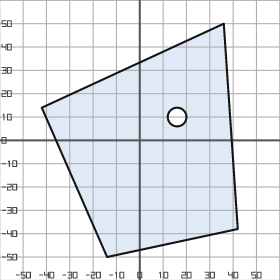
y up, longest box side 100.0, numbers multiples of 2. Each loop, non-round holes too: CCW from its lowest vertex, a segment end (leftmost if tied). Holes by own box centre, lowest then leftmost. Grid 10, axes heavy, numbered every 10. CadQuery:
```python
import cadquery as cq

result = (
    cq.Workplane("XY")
    .moveTo(-14.0, -50.0)
    .lineTo(42.0, -38.0)
    .lineTo(36.0, 50.0)
    .lineTo(-42.0, 14.0)
    .close()
    .moveTo(16.0, 10.0)
    .circle(4.0)
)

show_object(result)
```